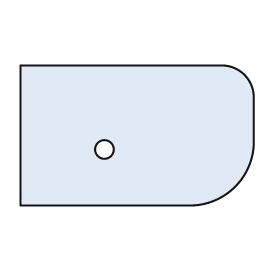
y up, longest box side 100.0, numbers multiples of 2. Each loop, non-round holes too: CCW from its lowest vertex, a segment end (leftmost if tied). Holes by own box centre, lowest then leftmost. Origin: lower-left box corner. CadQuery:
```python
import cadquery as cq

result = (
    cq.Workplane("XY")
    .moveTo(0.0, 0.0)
    .lineTo(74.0, 0.0)
    .threePointArc((92.0, 8.0), (100.0, 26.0))
    .lineTo(100.0, 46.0)
    .threePointArc((96.0, 56.0), (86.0, 60.0))
    .lineTo(0.0, 60.0)
    .close()
    .moveTo(36.0, 24.0)
    .circle(4.0)
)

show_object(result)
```